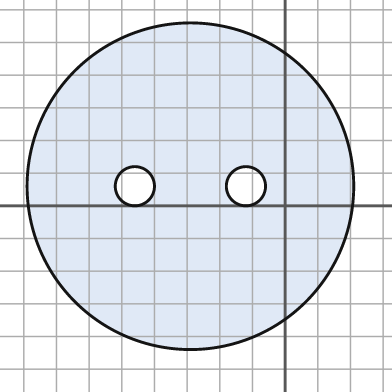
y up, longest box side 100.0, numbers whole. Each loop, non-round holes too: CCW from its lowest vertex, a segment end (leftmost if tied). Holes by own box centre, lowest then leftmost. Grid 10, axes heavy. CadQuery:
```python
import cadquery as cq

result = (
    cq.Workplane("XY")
    .moveTo(-29.0, 6.0)
    .circle(50.0)
    .moveTo(-46.0, 6.0)
    .circle(6.0)
    .moveTo(-12.0, 6.0)
    .circle(6.0)
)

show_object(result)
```